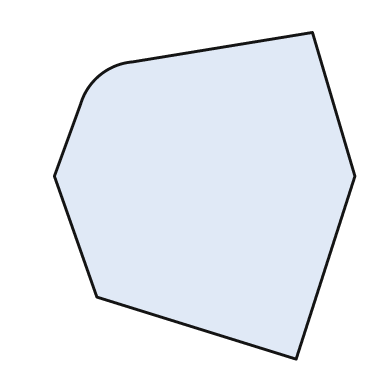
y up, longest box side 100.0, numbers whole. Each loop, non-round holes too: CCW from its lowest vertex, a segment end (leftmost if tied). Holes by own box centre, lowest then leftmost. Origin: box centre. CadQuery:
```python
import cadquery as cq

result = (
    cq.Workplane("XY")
    .moveTo(28.0, -50.0)
    .lineTo(46.0, 6.0)
    .lineTo(33.0, 50.0)
    .lineTo(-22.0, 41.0)
    .threePointArc((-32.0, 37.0), (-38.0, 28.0))
    .lineTo(-46.0, 6.0)
    .lineTo(-33.0, -31.0)
    .close()
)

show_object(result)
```